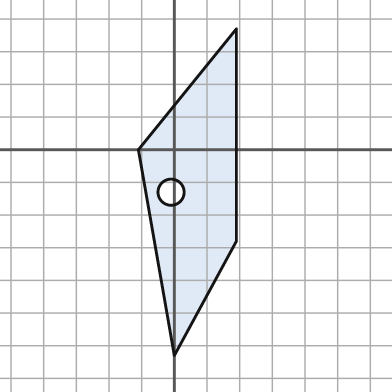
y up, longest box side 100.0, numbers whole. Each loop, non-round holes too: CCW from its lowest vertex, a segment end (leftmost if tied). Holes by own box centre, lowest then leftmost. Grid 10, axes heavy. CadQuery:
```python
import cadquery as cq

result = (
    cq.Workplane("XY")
    .moveTo(0.0, -63.0)
    .lineTo(19.0, -28.0)
    .lineTo(19.0, 37.0)
    .lineTo(-11.0, 0.0)
    .close()
    .moveTo(-1.0, -13.0)
    .circle(4.0)
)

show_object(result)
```